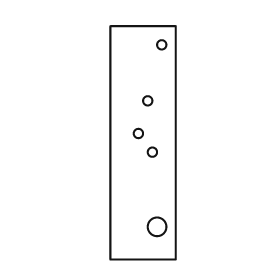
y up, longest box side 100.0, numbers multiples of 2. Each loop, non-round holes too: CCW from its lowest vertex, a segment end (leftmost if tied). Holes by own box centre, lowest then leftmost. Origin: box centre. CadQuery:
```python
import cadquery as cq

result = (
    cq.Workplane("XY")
    .moveTo(-14.0, -50.0)
    .lineTo(14.0, -50.0)
    .lineTo(14.0, 50.0)
    .lineTo(-14.0, 50.0)
    .close()
    .moveTo(6.0, -36.0)
    .circle(4.0)
    .moveTo(4.0, -4.0)
    .circle(2.0)
    .moveTo(-2.0, 4.0)
    .circle(2.0)
    .moveTo(2.0, 18.0)
    .circle(2.0)
    .moveTo(8.0, 42.0)
    .circle(2.0)
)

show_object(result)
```